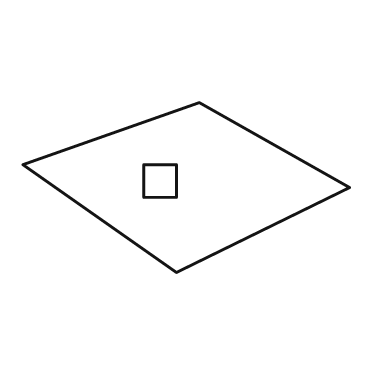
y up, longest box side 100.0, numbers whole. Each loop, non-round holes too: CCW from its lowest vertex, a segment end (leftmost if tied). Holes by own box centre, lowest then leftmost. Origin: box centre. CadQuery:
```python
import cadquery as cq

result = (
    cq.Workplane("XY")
    .moveTo(-3.0, -26.0)
    .lineTo(50.0, 0.0)
    .lineTo(4.0, 26.0)
    .lineTo(-50.0, 7.0)
    .close()
    .moveTo(-13.0, -3.0)
    .lineTo(-3.0, -3.0)
    .lineTo(-3.0, 7.0)
    .lineTo(-13.0, 7.0)
    .close()
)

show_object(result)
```